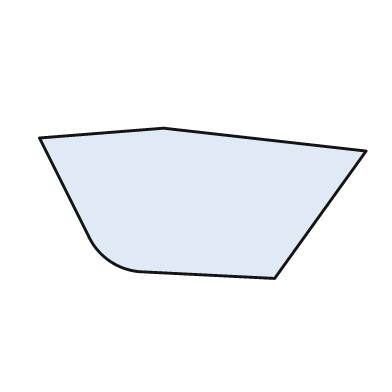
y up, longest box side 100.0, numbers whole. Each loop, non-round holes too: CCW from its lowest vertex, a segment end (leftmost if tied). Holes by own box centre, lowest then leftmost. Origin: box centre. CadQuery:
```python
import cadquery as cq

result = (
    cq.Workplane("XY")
    .moveTo(22.0, -23.0)
    .lineTo(50.0, 16.0)
    .lineTo(-12.0, 23.0)
    .lineTo(-50.0, 20.0)
    .lineTo(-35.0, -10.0)
    .threePointArc((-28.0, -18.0), (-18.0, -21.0))
    .close()
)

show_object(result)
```